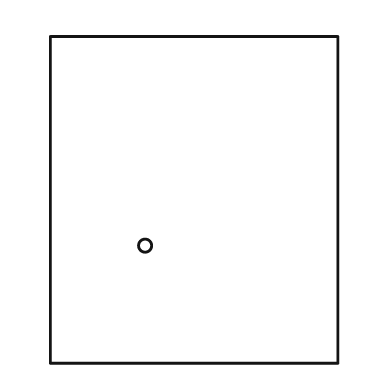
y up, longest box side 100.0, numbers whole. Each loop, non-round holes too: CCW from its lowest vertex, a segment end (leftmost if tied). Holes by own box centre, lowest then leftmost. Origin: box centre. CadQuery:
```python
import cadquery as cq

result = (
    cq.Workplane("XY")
    .moveTo(-44.0, -50.0)
    .lineTo(44.0, -50.0)
    .lineTo(44.0, 50.0)
    .lineTo(-44.0, 50.0)
    .close()
    .moveTo(-15.0, -14.0)
    .circle(2.0)
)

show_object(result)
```